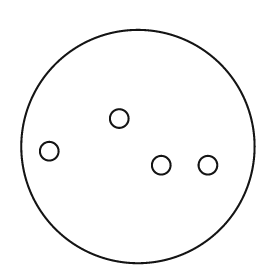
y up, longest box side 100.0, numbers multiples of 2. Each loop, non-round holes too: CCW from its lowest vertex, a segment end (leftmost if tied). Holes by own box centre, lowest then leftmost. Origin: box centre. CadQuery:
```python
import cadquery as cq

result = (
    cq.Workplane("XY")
    .moveTo(0.0, 0.0)
    .circle(50.0)
    .moveTo(10.0, -8.0)
    .circle(4.0)
    .moveTo(30.0, -8.0)
    .circle(4.0)
    .moveTo(-38.0, -2.0)
    .circle(4.0)
    .moveTo(-8.0, 12.0)
    .circle(4.0)
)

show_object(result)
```